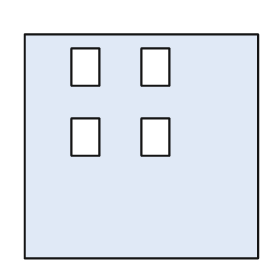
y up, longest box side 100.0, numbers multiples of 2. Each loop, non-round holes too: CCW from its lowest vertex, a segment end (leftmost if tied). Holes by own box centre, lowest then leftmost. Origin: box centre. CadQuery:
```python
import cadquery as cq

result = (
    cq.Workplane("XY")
    .moveTo(-50.0, -48.0)
    .lineTo(50.0, -48.0)
    .lineTo(50.0, 48.0)
    .lineTo(-50.0, 48.0)
    .close()
    .moveTo(-30.0, -4.0)
    .lineTo(-18.0, -4.0)
    .lineTo(-18.0, 12.0)
    .lineTo(-30.0, 12.0)
    .close()
    .moveTo(0.0, -4.0)
    .lineTo(12.0, -4.0)
    .lineTo(12.0, 12.0)
    .lineTo(0.0, 12.0)
    .close()
    .moveTo(-30.0, 26.0)
    .lineTo(-18.0, 26.0)
    .lineTo(-18.0, 42.0)
    .lineTo(-30.0, 42.0)
    .close()
    .moveTo(0.0, 26.0)
    .lineTo(12.0, 26.0)
    .lineTo(12.0, 42.0)
    .lineTo(0.0, 42.0)
    .close()
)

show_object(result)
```